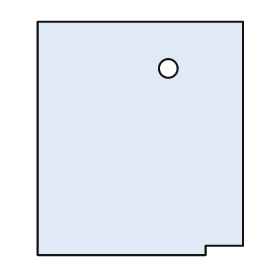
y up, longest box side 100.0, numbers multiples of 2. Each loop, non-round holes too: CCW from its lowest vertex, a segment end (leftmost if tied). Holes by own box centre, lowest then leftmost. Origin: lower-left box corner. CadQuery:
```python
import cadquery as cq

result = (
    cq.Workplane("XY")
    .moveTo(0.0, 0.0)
    .lineTo(72.0, 0.0)
    .lineTo(72.0, 4.0)
    .lineTo(88.0, 4.0)
    .lineTo(88.0, 100.0)
    .lineTo(0.0, 100.0)
    .close()
    .moveTo(56.0, 80.0)
    .circle(4.0)
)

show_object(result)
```